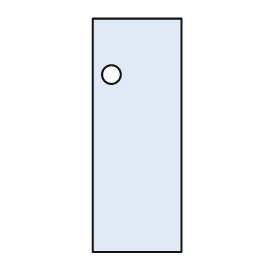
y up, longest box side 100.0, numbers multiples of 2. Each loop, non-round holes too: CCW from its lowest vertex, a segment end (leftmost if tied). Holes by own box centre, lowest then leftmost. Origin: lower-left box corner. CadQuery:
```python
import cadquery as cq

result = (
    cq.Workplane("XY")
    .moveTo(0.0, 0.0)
    .lineTo(38.0, 0.0)
    .lineTo(38.0, 100.0)
    .lineTo(0.0, 100.0)
    .close()
    .moveTo(8.0, 76.0)
    .circle(4.0)
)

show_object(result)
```